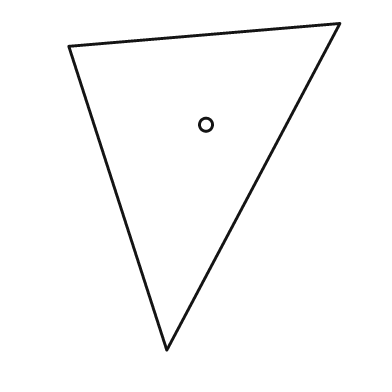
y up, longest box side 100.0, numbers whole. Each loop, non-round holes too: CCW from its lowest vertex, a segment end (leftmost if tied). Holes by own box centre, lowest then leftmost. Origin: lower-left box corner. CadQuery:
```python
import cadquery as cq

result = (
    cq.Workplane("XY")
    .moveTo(30.0, 0.0)
    .lineTo(83.0, 100.0)
    .lineTo(0.0, 93.0)
    .close()
    .moveTo(42.0, 69.0)
    .circle(2.0)
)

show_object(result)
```